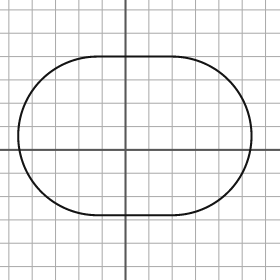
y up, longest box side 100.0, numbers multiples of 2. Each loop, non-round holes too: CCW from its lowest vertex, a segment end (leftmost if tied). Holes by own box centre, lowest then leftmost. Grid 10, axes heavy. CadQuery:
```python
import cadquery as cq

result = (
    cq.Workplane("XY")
    .moveTo(-12.0, -28.0)
    .lineTo(20.0, -28.0)
    .threePointArc((54.0, 6.0), (20.0, 40.0))
    .lineTo(-12.0, 40.0)
    .threePointArc((-46.0, 6.0), (-12.0, -28.0))
    .close()
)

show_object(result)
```